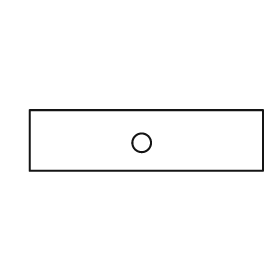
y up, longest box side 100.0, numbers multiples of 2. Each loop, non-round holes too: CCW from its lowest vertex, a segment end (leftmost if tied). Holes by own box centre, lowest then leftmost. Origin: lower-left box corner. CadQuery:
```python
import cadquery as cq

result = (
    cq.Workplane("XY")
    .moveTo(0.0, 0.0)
    .lineTo(100.0, 0.0)
    .lineTo(100.0, 26.0)
    .lineTo(0.0, 26.0)
    .close()
    .moveTo(48.0, 12.0)
    .circle(4.0)
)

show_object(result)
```